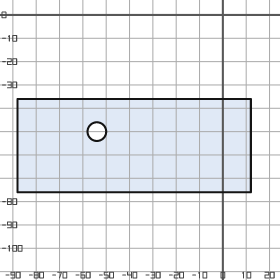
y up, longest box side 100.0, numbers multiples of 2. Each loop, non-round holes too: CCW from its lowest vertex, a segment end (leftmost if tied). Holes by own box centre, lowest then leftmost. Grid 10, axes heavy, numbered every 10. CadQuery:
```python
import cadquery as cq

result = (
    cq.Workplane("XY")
    .moveTo(-88.0, -76.0)
    .lineTo(12.0, -76.0)
    .lineTo(12.0, -36.0)
    .lineTo(-88.0, -36.0)
    .close()
    .moveTo(-54.0, -50.0)
    .circle(4.0)
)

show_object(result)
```